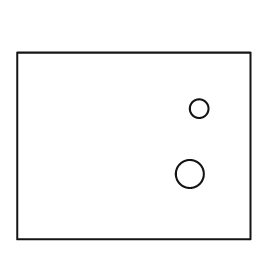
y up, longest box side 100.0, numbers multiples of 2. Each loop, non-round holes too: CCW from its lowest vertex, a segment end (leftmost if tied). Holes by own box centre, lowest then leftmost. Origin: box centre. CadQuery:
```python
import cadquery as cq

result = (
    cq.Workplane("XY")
    .moveTo(-50.0, -40.0)
    .lineTo(50.0, -40.0)
    .lineTo(50.0, 40.0)
    .lineTo(-50.0, 40.0)
    .close()
    .moveTo(24.0, -12.0)
    .circle(6.0)
    .moveTo(28.0, 16.0)
    .circle(4.0)
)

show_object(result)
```